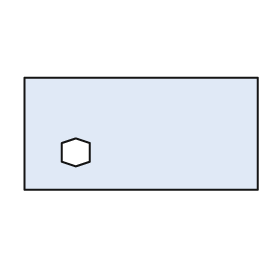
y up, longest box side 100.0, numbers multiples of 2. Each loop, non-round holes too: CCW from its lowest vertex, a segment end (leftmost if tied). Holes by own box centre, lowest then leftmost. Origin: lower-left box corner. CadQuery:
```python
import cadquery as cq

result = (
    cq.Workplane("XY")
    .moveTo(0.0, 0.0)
    .lineTo(100.0, 0.0)
    .lineTo(100.0, 48.0)
    .lineTo(0.0, 48.0)
    .close()
    .moveTo(22.0, 10.0)
    .lineTo(28.0, 12.0)
    .lineTo(28.0, 20.0)
    .lineTo(22.0, 22.0)
    .lineTo(16.0, 20.0)
    .lineTo(16.0, 12.0)
    .close()
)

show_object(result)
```